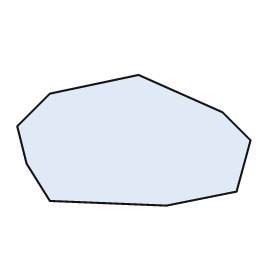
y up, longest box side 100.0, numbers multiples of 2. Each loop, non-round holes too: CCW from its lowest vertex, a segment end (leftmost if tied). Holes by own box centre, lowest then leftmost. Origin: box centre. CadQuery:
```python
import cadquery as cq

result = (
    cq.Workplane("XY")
    .moveTo(14.0, -28.0)
    .lineTo(44.0, -22.0)
    .lineTo(50.0, 0.0)
    .lineTo(38.0, 12.0)
    .lineTo(2.0, 28.0)
    .lineTo(-36.0, 20.0)
    .lineTo(-50.0, 6.0)
    .lineTo(-46.0, -10.0)
    .lineTo(-36.0, -26.0)
    .close()
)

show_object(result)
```